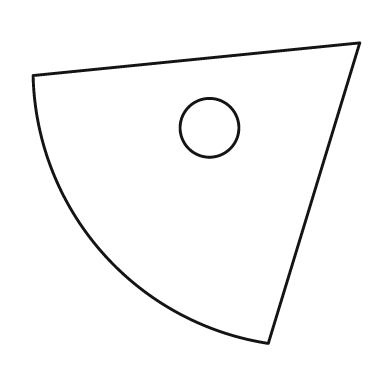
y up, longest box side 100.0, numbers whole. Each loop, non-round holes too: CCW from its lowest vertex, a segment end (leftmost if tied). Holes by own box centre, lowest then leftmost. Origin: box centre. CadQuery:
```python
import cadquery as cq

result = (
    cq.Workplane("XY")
    .moveTo(22.0, -46.0)
    .lineTo(50.0, 46.0)
    .lineTo(-50.0, 36.0)
    .threePointArc((-29.0, -18.0), (22.0, -46.0))
    .close()
    .moveTo(4.0, 20.0)
    .circle(9.0)
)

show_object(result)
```